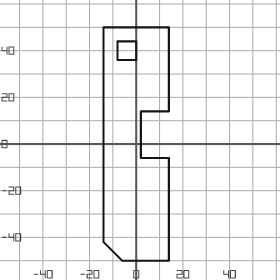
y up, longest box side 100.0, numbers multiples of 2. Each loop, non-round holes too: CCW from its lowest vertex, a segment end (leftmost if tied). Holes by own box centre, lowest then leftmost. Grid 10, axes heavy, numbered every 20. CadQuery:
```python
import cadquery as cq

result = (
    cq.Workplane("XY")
    .moveTo(-6.0, -50.0)
    .lineTo(14.0, -50.0)
    .lineTo(14.0, -6.0)
    .lineTo(2.0, -6.0)
    .lineTo(2.0, 14.0)
    .lineTo(14.0, 14.0)
    .lineTo(14.0, 50.0)
    .lineTo(-14.0, 50.0)
    .lineTo(-14.0, -42.0)
    .close()
    .moveTo(-8.0, 36.0)
    .lineTo(0.0, 36.0)
    .lineTo(0.0, 44.0)
    .lineTo(-8.0, 44.0)
    .close()
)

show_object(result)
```